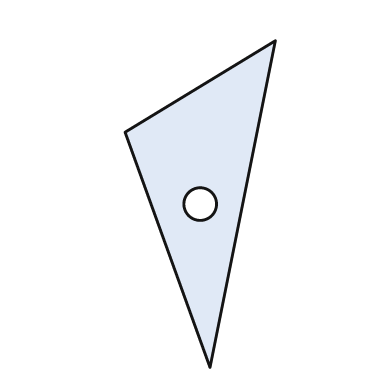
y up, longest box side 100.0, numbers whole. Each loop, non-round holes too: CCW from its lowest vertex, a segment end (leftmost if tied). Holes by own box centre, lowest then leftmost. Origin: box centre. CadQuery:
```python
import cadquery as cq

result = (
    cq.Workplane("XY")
    .moveTo(3.0, -50.0)
    .lineTo(23.0, 50.0)
    .lineTo(-23.0, 22.0)
    .close()
    .moveTo(0.0, 0.0)
    .circle(5.0)
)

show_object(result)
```